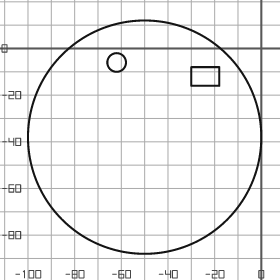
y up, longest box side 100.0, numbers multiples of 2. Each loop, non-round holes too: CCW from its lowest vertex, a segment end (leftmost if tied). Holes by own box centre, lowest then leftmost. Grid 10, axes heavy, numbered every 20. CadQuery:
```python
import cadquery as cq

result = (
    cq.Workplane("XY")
    .moveTo(-50.0, -38.0)
    .circle(50.0)
    .moveTo(-30.0, -16.0)
    .lineTo(-18.0, -16.0)
    .lineTo(-18.0, -8.0)
    .lineTo(-30.0, -8.0)
    .close()
    .moveTo(-62.0, -6.0)
    .circle(4.0)
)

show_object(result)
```